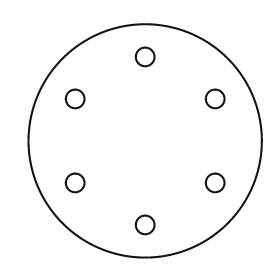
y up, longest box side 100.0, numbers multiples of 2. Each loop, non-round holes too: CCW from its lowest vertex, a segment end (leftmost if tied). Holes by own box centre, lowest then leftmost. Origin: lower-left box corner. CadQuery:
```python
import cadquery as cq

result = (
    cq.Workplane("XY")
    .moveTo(50.0, 50.0)
    .circle(50.0)
    .moveTo(50.0, 14.0)
    .circle(4.0)
    .moveTo(20.0, 32.0)
    .circle(4.0)
    .moveTo(80.0, 32.0)
    .circle(4.0)
    .moveTo(20.0, 68.0)
    .circle(4.0)
    .moveTo(80.0, 68.0)
    .circle(4.0)
    .moveTo(50.0, 86.0)
    .circle(4.0)
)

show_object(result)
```